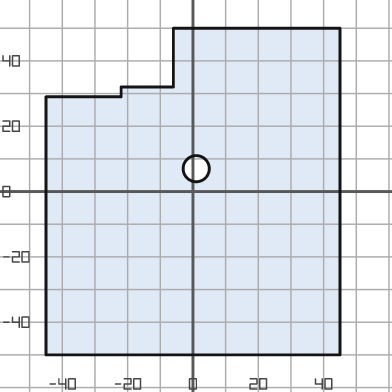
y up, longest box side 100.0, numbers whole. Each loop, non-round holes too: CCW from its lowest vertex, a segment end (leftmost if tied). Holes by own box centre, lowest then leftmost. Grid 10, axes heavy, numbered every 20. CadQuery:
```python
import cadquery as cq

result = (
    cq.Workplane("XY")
    .moveTo(-45.0, -50.0)
    .lineTo(45.0, -50.0)
    .lineTo(45.0, 50.0)
    .lineTo(-6.0, 50.0)
    .lineTo(-6.0, 32.0)
    .lineTo(-22.0, 32.0)
    .lineTo(-22.0, 29.0)
    .lineTo(-45.0, 29.0)
    .close()
    .moveTo(1.0, 7.0)
    .circle(4.0)
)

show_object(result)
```